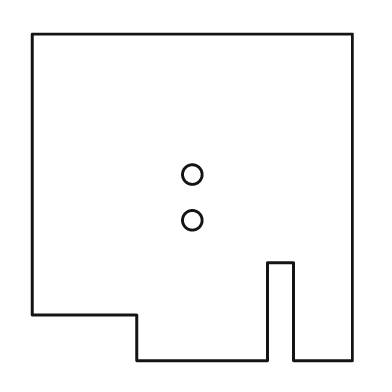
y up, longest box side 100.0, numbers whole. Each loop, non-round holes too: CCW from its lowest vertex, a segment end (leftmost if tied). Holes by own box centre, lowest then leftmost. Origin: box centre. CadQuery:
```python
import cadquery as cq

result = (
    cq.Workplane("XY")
    .moveTo(-17.0, -50.0)
    .lineTo(23.0, -50.0)
    .lineTo(23.0, -20.0)
    .lineTo(31.0, -20.0)
    .lineTo(31.0, -50.0)
    .lineTo(49.0, -50.0)
    .lineTo(49.0, 50.0)
    .lineTo(-49.0, 50.0)
    .lineTo(-49.0, -36.0)
    .lineTo(-17.0, -36.0)
    .close()
    .moveTo(0.0, -7.0)
    .circle(3.0)
    .moveTo(0.0, 7.0)
    .circle(3.0)
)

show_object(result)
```